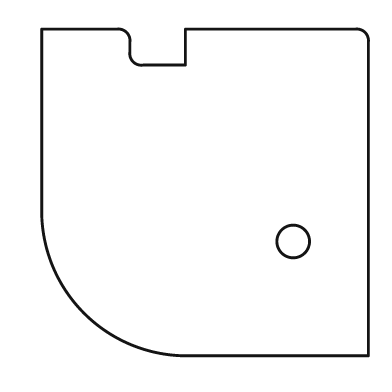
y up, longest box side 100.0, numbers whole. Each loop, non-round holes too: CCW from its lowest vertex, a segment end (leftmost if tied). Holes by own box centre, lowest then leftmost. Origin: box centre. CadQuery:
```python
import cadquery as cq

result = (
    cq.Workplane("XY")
    .moveTo(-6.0, -50.0)
    .lineTo(50.0, -50.0)
    .lineTo(50.0, 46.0)
    .threePointArc((49.0, 49.0), (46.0, 50.0))
    .lineTo(-6.0, 50.0)
    .lineTo(-6.0, 39.0)
    .lineTo(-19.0, 39.0)
    .threePointArc((-22.0, 40.0), (-23.0, 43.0))
    .lineTo(-23.0, 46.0)
    .threePointArc((-24.0, 49.0), (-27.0, 50.0))
    .lineTo(-50.0, 50.0)
    .lineTo(-50.0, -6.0)
    .threePointArc((-37.0, -37.0), (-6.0, -50.0))
    .close()
    .moveTo(27.0, -15.0)
    .circle(5.0)
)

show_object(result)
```